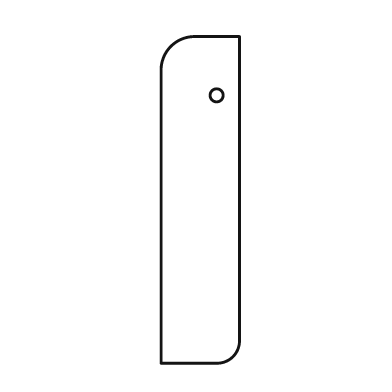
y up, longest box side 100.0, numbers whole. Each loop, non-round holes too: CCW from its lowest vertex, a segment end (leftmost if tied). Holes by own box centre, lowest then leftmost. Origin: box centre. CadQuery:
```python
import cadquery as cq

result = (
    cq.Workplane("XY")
    .moveTo(-12.0, -50.0)
    .lineTo(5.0, -50.0)
    .threePointArc((10.0, -48.0), (12.0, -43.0))
    .lineTo(12.0, 50.0)
    .lineTo(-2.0, 50.0)
    .threePointArc((-9.0, 47.0), (-12.0, 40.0))
    .close()
    .moveTo(5.0, 32.0)
    .circle(2.0)
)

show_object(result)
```